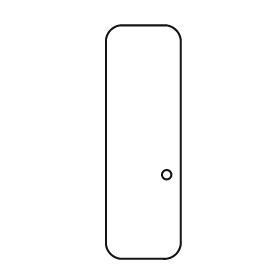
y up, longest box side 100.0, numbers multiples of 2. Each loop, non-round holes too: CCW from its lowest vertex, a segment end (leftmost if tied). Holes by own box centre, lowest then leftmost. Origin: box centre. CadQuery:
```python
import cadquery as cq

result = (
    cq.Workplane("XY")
    .moveTo(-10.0, -50.0)
    .lineTo(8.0, -50.0)
    .threePointArc((14.0, -48.0), (16.0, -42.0))
    .lineTo(16.0, 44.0)
    .threePointArc((14.0, 48.0), (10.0, 50.0))
    .lineTo(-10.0, 50.0)
    .threePointArc((-14.0, 48.0), (-16.0, 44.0))
    .lineTo(-16.0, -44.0)
    .threePointArc((-14.0, -48.0), (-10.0, -50.0))
    .close()
    .moveTo(10.0, -14.0)
    .circle(2.0)
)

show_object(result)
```